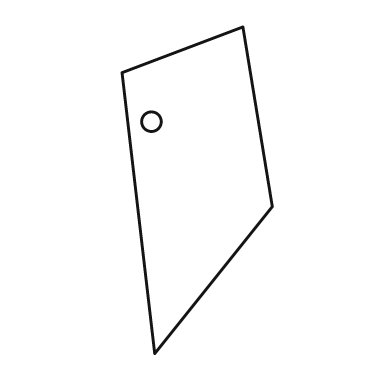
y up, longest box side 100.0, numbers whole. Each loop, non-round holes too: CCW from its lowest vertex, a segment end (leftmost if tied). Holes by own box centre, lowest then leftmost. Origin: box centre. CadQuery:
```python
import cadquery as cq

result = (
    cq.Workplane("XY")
    .moveTo(-13.0, -50.0)
    .lineTo(23.0, -5.0)
    .lineTo(14.0, 50.0)
    .lineTo(-23.0, 36.0)
    .close()
    .moveTo(-14.0, 21.0)
    .circle(3.0)
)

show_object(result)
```